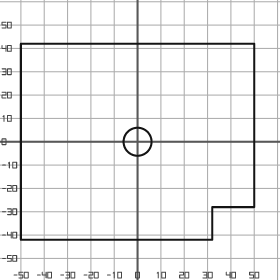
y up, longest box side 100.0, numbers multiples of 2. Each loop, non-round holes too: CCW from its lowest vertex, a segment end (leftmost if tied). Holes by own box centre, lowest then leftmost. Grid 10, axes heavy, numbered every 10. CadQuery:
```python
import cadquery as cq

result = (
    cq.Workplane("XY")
    .moveTo(-50.0, -42.0)
    .lineTo(32.0, -42.0)
    .lineTo(32.0, -28.0)
    .lineTo(50.0, -28.0)
    .lineTo(50.0, 42.0)
    .lineTo(-50.0, 42.0)
    .close()
    .moveTo(0.0, 0.0)
    .circle(6.0)
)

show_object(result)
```